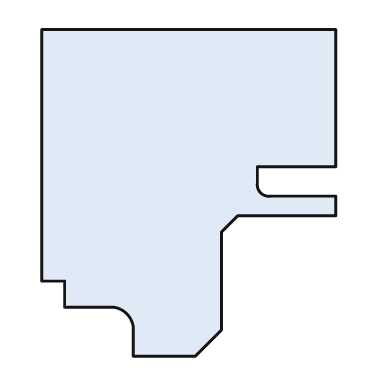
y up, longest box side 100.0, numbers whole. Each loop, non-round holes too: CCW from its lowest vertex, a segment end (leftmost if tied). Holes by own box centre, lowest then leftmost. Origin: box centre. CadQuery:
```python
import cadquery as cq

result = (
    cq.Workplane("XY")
    .moveTo(-17.0, -50.0)
    .lineTo(2.0, -50.0)
    .lineTo(10.0, -42.0)
    .lineTo(10.0, -12.0)
    .lineTo(15.0, -7.0)
    .lineTo(45.0, -7.0)
    .lineTo(45.0, -1.0)
    .lineTo(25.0, -1.0)
    .threePointArc((22.0, 0.0), (21.0, 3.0))
    .lineTo(21.0, 8.0)
    .lineTo(45.0, 8.0)
    .lineTo(45.0, 50.0)
    .lineTo(-45.0, 50.0)
    .lineTo(-45.0, -27.0)
    .lineTo(-38.0, -27.0)
    .lineTo(-38.0, -35.0)
    .lineTo(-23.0, -35.0)
    .threePointArc((-19.0, -37.0), (-17.0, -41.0))
    .close()
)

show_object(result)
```